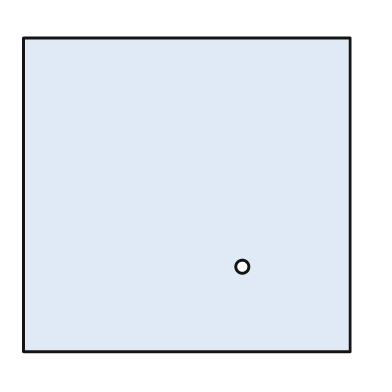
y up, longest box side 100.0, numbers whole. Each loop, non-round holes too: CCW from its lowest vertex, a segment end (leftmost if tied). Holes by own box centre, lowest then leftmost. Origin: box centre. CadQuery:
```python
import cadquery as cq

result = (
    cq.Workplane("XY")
    .moveTo(-50.0, -48.0)
    .lineTo(50.0, -48.0)
    .lineTo(50.0, 48.0)
    .lineTo(-50.0, 48.0)
    .close()
    .moveTo(17.0, -22.0)
    .circle(2.0)
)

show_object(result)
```